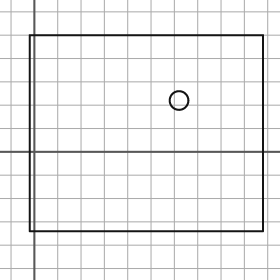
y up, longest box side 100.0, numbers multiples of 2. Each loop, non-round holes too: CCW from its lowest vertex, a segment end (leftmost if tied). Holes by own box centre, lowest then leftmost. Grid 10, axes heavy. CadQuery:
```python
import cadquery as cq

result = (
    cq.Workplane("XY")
    .moveTo(-2.0, -34.0)
    .lineTo(98.0, -34.0)
    .lineTo(98.0, 50.0)
    .lineTo(-2.0, 50.0)
    .close()
    .moveTo(62.0, 22.0)
    .circle(4.0)
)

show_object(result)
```